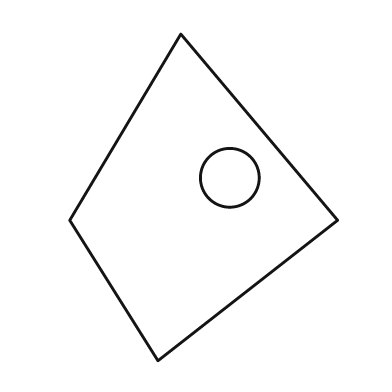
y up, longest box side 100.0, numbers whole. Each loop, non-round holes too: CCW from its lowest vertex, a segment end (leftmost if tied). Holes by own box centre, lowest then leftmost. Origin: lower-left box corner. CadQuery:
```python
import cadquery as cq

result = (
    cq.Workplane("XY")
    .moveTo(27.0, 0.0)
    .lineTo(82.0, 43.0)
    .lineTo(34.0, 100.0)
    .lineTo(0.0, 43.0)
    .close()
    .moveTo(49.0, 56.0)
    .circle(9.0)
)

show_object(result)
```